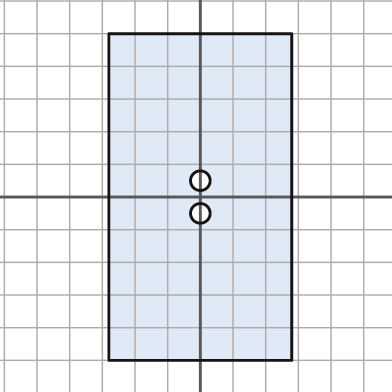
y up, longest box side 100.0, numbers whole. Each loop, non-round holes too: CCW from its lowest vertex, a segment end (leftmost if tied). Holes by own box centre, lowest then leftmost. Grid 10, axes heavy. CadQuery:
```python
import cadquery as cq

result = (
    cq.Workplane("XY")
    .moveTo(-28.0, -50.0)
    .lineTo(28.0, -50.0)
    .lineTo(28.0, 50.0)
    .lineTo(-28.0, 50.0)
    .close()
    .moveTo(0.0, -5.0)
    .circle(3.0)
    .moveTo(0.0, 5.0)
    .circle(3.0)
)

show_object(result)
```